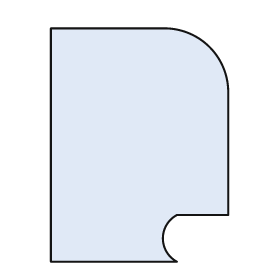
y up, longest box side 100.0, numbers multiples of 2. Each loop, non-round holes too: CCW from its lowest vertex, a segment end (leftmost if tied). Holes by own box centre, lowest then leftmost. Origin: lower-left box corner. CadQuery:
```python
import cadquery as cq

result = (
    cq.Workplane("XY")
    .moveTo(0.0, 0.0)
    .lineTo(54.0, 0.0)
    .threePointArc((48.0, 10.0), (54.0, 20.0))
    .lineTo(76.0, 20.0)
    .lineTo(76.0, 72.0)
    .threePointArc((68.0, 92.0), (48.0, 100.0))
    .lineTo(0.0, 100.0)
    .close()
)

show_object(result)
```